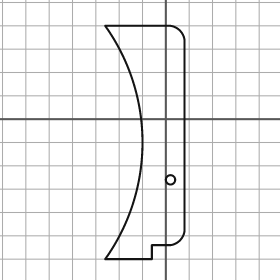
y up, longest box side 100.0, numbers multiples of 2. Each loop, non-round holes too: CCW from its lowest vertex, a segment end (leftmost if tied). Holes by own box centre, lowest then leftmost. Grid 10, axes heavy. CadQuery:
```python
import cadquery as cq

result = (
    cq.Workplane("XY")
    .moveTo(-26.0, -60.0)
    .lineTo(-6.0, -60.0)
    .lineTo(-6.0, -54.0)
    .lineTo(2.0, -54.0)
    .threePointArc((6.0, -52.0), (8.0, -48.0))
    .lineTo(8.0, 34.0)
    .threePointArc((6.0, 38.0), (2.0, 40.0))
    .lineTo(-26.0, 40.0)
    .threePointArc((-10.0, -10.0), (-26.0, -60.0))
    .close()
    .moveTo(2.0, -26.0)
    .circle(2.0)
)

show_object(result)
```